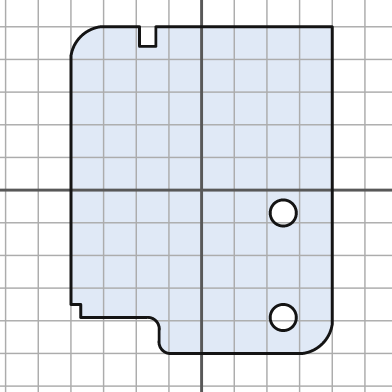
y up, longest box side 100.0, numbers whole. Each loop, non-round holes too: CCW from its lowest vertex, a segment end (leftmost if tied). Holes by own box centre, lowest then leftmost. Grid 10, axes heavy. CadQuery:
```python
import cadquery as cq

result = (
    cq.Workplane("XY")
    .moveTo(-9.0, -50.0)
    .lineTo(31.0, -50.0)
    .threePointArc((37.0, -47.0), (40.0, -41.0))
    .lineTo(40.0, 50.0)
    .lineTo(-14.0, 50.0)
    .lineTo(-14.0, 44.0)
    .lineTo(-19.0, 44.0)
    .lineTo(-19.0, 50.0)
    .lineTo(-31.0, 50.0)
    .threePointArc((-37.0, 47.0), (-40.0, 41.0))
    .lineTo(-40.0, -35.0)
    .lineTo(-37.0, -35.0)
    .lineTo(-37.0, -39.0)
    .lineTo(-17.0, -39.0)
    .threePointArc((-14.0, -40.0), (-13.0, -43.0))
    .lineTo(-13.0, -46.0)
    .threePointArc((-12.0, -49.0), (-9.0, -50.0))
    .close()
    .moveTo(25.0, -39.0)
    .circle(4.0)
    .moveTo(25.0, -7.0)
    .circle(4.0)
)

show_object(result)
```